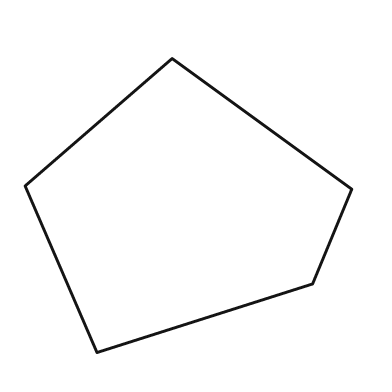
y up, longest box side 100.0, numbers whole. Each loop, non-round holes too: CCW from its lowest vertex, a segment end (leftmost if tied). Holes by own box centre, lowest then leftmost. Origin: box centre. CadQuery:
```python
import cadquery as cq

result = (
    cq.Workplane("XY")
    .moveTo(-28.0, -45.0)
    .lineTo(38.0, -24.0)
    .lineTo(50.0, 5.0)
    .lineTo(-5.0, 45.0)
    .lineTo(-50.0, 6.0)
    .close()
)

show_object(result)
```